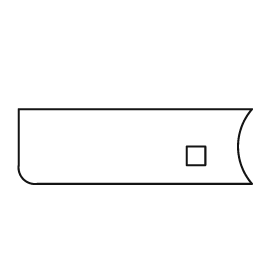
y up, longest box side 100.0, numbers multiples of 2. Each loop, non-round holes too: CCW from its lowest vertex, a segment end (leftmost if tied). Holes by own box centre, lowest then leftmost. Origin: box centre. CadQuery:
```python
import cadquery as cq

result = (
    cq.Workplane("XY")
    .moveTo(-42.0, -16.0)
    .lineTo(50.0, -16.0)
    .threePointArc((44.0, 0.0), (50.0, 16.0))
    .lineTo(-50.0, 16.0)
    .lineTo(-50.0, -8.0)
    .threePointArc((-48.0, -14.0), (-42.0, -16.0))
    .close()
    .moveTo(22.0, -8.0)
    .lineTo(30.0, -8.0)
    .lineTo(30.0, 0.0)
    .lineTo(22.0, 0.0)
    .close()
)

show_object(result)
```